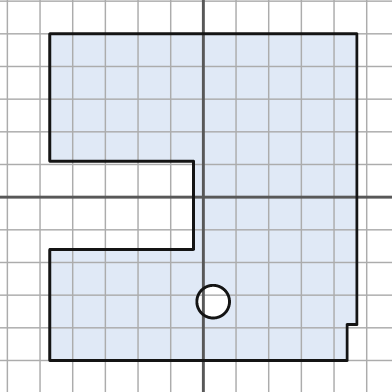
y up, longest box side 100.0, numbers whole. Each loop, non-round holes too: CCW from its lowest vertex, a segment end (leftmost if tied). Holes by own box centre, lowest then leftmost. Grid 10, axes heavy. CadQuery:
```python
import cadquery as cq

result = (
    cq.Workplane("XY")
    .moveTo(-47.0, -50.0)
    .lineTo(44.0, -50.0)
    .lineTo(44.0, -39.0)
    .lineTo(47.0, -39.0)
    .lineTo(47.0, 50.0)
    .lineTo(-47.0, 50.0)
    .lineTo(-47.0, 11.0)
    .lineTo(-3.0, 11.0)
    .lineTo(-3.0, -16.0)
    .lineTo(-47.0, -16.0)
    .close()
    .moveTo(3.0, -32.0)
    .circle(5.0)
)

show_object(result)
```